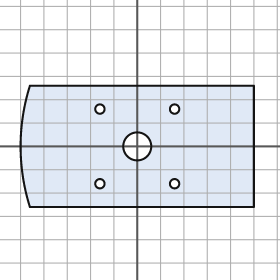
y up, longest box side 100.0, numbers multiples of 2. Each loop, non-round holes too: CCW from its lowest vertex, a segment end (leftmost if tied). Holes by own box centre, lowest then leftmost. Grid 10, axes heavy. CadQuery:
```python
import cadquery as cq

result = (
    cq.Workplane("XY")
    .moveTo(-46.0, -26.0)
    .lineTo(50.0, -26.0)
    .lineTo(50.0, 26.0)
    .lineTo(-46.0, 26.0)
    .threePointArc((-50.0, 0.0), (-46.0, -26.0))
    .close()
    .moveTo(-16.0, -16.0)
    .circle(2.0)
    .moveTo(16.0, -16.0)
    .circle(2.0)
    .moveTo(0.0, 0.0)
    .circle(6.0)
    .moveTo(-16.0, 16.0)
    .circle(2.0)
    .moveTo(16.0, 16.0)
    .circle(2.0)
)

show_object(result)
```